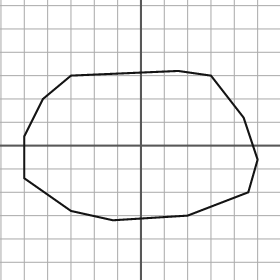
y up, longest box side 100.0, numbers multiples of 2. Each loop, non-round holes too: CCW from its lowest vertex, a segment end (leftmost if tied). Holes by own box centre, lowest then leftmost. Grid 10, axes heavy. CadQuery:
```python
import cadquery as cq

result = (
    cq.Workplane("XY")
    .moveTo(-12.0, -32.0)
    .lineTo(20.0, -30.0)
    .lineTo(46.0, -20.0)
    .lineTo(50.0, -6.0)
    .lineTo(44.0, 12.0)
    .lineTo(30.0, 30.0)
    .lineTo(16.0, 32.0)
    .lineTo(-30.0, 30.0)
    .lineTo(-42.0, 20.0)
    .lineTo(-50.0, 4.0)
    .lineTo(-50.0, -14.0)
    .lineTo(-30.0, -28.0)
    .close()
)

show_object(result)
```